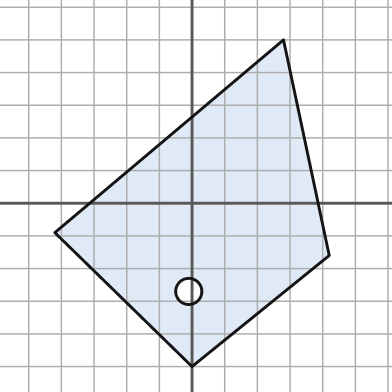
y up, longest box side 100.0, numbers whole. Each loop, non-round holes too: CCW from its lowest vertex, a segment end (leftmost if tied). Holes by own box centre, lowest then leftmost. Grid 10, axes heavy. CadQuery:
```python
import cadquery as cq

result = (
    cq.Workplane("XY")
    .moveTo(0.0, -50.0)
    .lineTo(42.0, -16.0)
    .lineTo(28.0, 50.0)
    .lineTo(-42.0, -9.0)
    .close()
    .moveTo(-1.0, -27.0)
    .circle(4.0)
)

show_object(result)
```